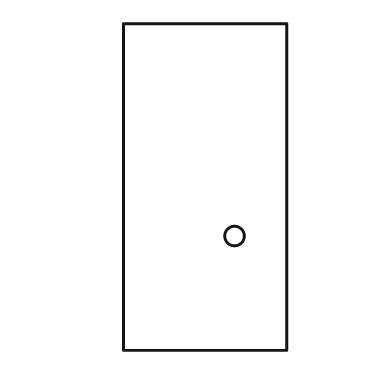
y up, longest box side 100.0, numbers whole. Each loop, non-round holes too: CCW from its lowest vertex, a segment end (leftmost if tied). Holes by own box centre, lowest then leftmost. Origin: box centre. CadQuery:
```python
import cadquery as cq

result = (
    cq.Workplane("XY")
    .moveTo(-25.0, -50.0)
    .lineTo(25.0, -50.0)
    .lineTo(25.0, 50.0)
    .lineTo(-25.0, 50.0)
    .close()
    .moveTo(9.0, -15.0)
    .circle(3.0)
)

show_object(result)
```